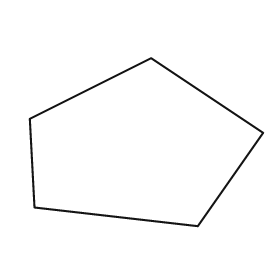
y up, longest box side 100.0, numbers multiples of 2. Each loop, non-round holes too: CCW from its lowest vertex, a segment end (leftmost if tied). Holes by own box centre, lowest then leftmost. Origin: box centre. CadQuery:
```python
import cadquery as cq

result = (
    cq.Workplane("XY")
    .moveTo(22.0, -36.0)
    .lineTo(50.0, 4.0)
    .lineTo(2.0, 36.0)
    .lineTo(-50.0, 10.0)
    .lineTo(-48.0, -28.0)
    .close()
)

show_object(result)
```